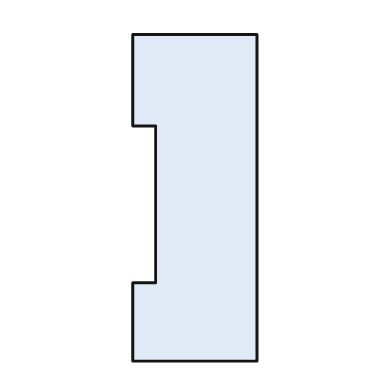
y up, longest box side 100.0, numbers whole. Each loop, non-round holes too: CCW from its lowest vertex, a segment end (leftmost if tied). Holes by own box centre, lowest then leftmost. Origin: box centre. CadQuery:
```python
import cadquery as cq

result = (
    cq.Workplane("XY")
    .moveTo(-19.0, -50.0)
    .lineTo(19.0, -50.0)
    .lineTo(19.0, 50.0)
    .lineTo(-19.0, 50.0)
    .lineTo(-19.0, 22.0)
    .lineTo(-12.0, 22.0)
    .lineTo(-12.0, -26.0)
    .lineTo(-19.0, -26.0)
    .close()
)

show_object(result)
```